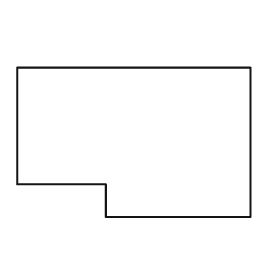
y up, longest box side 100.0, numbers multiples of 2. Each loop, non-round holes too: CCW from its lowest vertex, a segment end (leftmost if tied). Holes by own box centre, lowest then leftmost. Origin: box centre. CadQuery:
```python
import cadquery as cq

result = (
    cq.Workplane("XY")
    .moveTo(-12.0, -32.0)
    .lineTo(50.0, -32.0)
    .lineTo(50.0, 32.0)
    .lineTo(-50.0, 32.0)
    .lineTo(-50.0, -18.0)
    .lineTo(-12.0, -18.0)
    .close()
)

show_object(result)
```